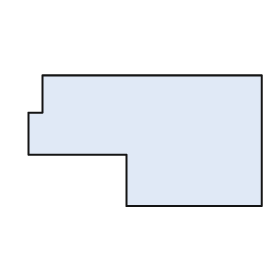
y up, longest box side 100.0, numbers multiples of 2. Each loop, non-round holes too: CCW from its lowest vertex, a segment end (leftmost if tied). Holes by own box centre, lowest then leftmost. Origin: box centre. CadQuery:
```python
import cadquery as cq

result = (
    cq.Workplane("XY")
    .moveTo(-8.0, -28.0)
    .lineTo(50.0, -28.0)
    .lineTo(50.0, 28.0)
    .lineTo(-44.0, 28.0)
    .lineTo(-44.0, 12.0)
    .lineTo(-50.0, 12.0)
    .lineTo(-50.0, -6.0)
    .lineTo(-8.0, -6.0)
    .close()
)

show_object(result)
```